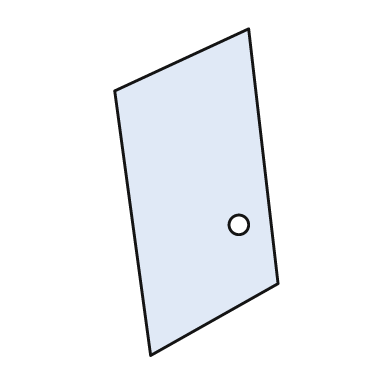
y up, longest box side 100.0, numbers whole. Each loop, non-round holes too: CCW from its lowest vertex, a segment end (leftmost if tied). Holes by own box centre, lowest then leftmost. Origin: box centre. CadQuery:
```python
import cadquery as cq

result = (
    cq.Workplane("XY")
    .moveTo(-14.0, -50.0)
    .lineTo(25.0, -28.0)
    .lineTo(16.0, 50.0)
    .lineTo(-25.0, 31.0)
    .close()
    .moveTo(13.0, -10.0)
    .circle(3.0)
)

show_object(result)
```